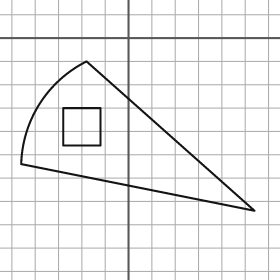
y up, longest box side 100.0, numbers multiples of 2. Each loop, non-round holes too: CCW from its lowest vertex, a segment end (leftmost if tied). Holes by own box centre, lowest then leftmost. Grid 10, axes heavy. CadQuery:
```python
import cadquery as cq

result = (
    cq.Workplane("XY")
    .moveTo(54.0, -74.0)
    .lineTo(-18.0, -10.0)
    .threePointArc((-38.0, -28.0), (-46.0, -54.0))
    .close()
    .moveTo(-28.0, -46.0)
    .lineTo(-12.0, -46.0)
    .lineTo(-12.0, -30.0)
    .lineTo(-28.0, -30.0)
    .close()
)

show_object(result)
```